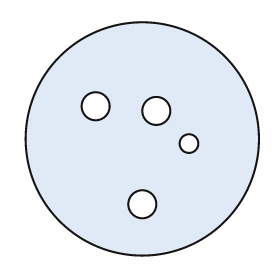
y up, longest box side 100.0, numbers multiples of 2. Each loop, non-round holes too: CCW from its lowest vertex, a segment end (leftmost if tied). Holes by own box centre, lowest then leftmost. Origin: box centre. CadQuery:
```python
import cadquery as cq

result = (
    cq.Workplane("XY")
    .moveTo(0.0, 0.0)
    .circle(50.0)
    .moveTo(0.0, -28.0)
    .circle(6.0)
    .moveTo(20.0, -2.0)
    .circle(4.0)
    .moveTo(6.0, 12.0)
    .circle(6.0)
    .moveTo(-20.0, 14.0)
    .circle(6.0)
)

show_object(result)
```